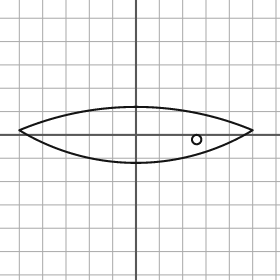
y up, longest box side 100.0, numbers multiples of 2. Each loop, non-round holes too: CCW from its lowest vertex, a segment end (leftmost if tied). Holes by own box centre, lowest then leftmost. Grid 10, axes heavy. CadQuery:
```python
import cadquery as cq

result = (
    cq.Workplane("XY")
    .moveTo(-50.0, 2.0)
    .threePointArc((0.0, -12.0), (50.0, 2.0))
    .threePointArc((0.0, 12.0), (-50.0, 2.0))
    .close()
    .moveTo(26.0, -2.0)
    .circle(2.0)
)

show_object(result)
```